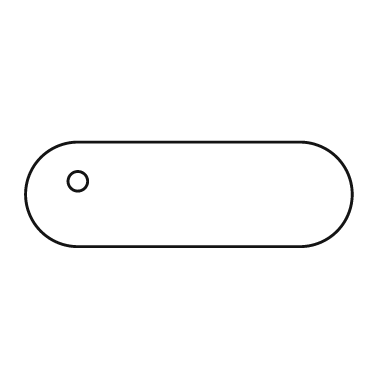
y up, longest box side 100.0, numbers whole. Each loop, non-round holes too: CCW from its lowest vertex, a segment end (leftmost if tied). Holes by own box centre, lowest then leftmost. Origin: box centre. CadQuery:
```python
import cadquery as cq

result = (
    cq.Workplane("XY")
    .moveTo(-34.0, -16.0)
    .lineTo(34.0, -16.0)
    .threePointArc((50.0, 0.0), (34.0, 16.0))
    .lineTo(-34.0, 16.0)
    .threePointArc((-50.0, 0.0), (-34.0, -16.0))
    .close()
    .moveTo(-34.0, 4.0)
    .circle(3.0)
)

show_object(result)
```